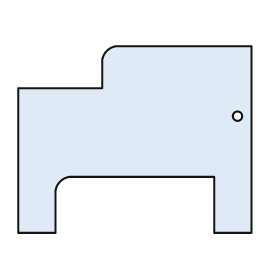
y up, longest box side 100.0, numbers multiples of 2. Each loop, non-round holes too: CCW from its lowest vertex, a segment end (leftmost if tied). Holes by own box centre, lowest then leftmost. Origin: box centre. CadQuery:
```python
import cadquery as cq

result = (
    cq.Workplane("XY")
    .moveTo(-50.0, -40.0)
    .lineTo(-34.0, -40.0)
    .lineTo(-34.0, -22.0)
    .threePointArc((-32.0, -18.0), (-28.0, -16.0))
    .lineTo(34.0, -16.0)
    .lineTo(34.0, -40.0)
    .lineTo(50.0, -40.0)
    .lineTo(50.0, 40.0)
    .lineTo(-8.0, 40.0)
    .threePointArc((-12.0, 38.0), (-14.0, 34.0))
    .lineTo(-14.0, 22.0)
    .lineTo(-50.0, 22.0)
    .close()
    .moveTo(44.0, 10.0)
    .circle(2.0)
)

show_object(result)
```